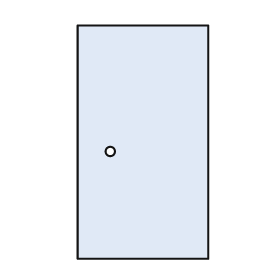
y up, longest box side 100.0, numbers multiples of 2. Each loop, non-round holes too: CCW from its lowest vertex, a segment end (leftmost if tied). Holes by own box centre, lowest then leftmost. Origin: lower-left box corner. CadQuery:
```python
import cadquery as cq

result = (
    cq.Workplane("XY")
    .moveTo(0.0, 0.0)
    .lineTo(56.0, 0.0)
    .lineTo(56.0, 100.0)
    .lineTo(0.0, 100.0)
    .close()
    .moveTo(14.0, 46.0)
    .circle(2.0)
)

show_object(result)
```